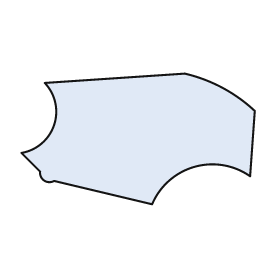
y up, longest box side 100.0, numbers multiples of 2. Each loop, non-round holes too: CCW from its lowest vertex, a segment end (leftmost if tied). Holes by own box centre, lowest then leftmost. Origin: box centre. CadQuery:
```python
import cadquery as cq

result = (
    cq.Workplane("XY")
    .moveTo(6.0, -28.0)
    .threePointArc((24.0, -12.0), (48.0, -16.0))
    .lineTo(50.0, 12.0)
    .threePointArc((36.0, 22.0), (20.0, 28.0))
    .lineTo(-40.0, 24.0)
    .threePointArc((-36.0, 6.0), (-50.0, -6.0))
    .lineTo(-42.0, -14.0)
    .threePointArc((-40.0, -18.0), (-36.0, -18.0))
    .close()
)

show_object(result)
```